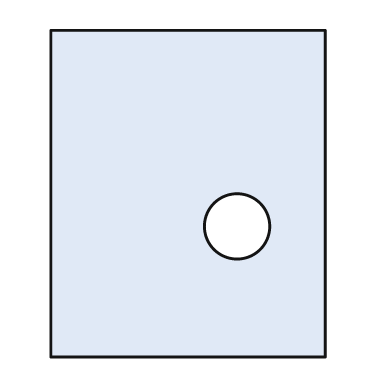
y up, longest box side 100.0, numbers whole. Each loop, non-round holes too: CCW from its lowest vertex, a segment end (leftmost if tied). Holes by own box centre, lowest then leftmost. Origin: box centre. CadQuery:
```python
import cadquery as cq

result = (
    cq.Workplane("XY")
    .moveTo(-42.0, -50.0)
    .lineTo(42.0, -50.0)
    .lineTo(42.0, 50.0)
    .lineTo(-42.0, 50.0)
    .close()
    .moveTo(15.0, -10.0)
    .circle(10.0)
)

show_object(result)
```